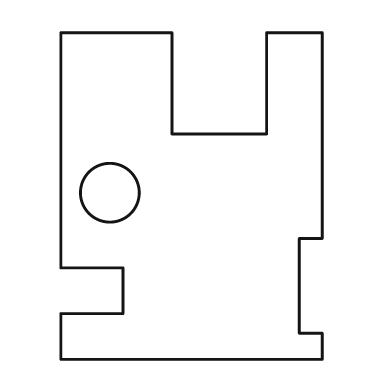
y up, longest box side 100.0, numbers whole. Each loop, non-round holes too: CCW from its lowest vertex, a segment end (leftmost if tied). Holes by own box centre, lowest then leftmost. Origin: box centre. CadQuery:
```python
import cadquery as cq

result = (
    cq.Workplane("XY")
    .moveTo(-40.0, -50.0)
    .lineTo(40.0, -50.0)
    .lineTo(40.0, -42.0)
    .lineTo(33.0, -42.0)
    .lineTo(33.0, -13.0)
    .lineTo(40.0, -13.0)
    .lineTo(40.0, 50.0)
    .lineTo(23.0, 50.0)
    .lineTo(23.0, 19.0)
    .lineTo(-6.0, 19.0)
    .lineTo(-6.0, 50.0)
    .lineTo(-40.0, 50.0)
    .lineTo(-40.0, -22.0)
    .lineTo(-21.0, -22.0)
    .lineTo(-21.0, -36.0)
    .lineTo(-40.0, -36.0)
    .close()
    .moveTo(-25.0, 1.0)
    .circle(9.0)
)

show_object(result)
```